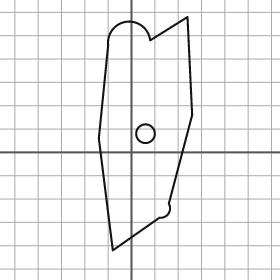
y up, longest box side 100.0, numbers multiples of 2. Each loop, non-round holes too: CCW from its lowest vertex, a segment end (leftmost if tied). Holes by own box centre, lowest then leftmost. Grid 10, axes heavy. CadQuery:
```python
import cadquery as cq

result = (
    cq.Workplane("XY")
    .moveTo(-8.0, -42.0)
    .lineTo(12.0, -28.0)
    .threePointArc((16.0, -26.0), (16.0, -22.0))
    .lineTo(26.0, 16.0)
    .lineTo(24.0, 58.0)
    .lineTo(8.0, 48.0)
    .threePointArc((-2.0, 56.0), (-10.0, 46.0))
    .lineTo(-14.0, 6.0)
    .close()
    .moveTo(6.0, 8.0)
    .circle(4.0)
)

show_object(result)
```